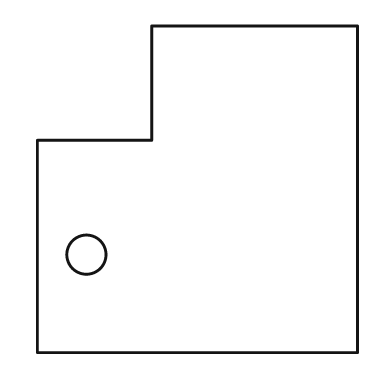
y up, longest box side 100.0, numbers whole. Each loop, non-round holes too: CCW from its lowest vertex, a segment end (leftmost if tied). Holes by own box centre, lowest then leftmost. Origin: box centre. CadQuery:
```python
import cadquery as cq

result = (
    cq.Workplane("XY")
    .moveTo(-49.0, -50.0)
    .lineTo(49.0, -50.0)
    .lineTo(49.0, 50.0)
    .lineTo(-14.0, 50.0)
    .lineTo(-14.0, 15.0)
    .lineTo(-49.0, 15.0)
    .close()
    .moveTo(-34.0, -20.0)
    .circle(6.0)
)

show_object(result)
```